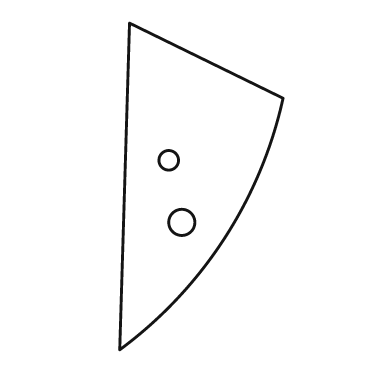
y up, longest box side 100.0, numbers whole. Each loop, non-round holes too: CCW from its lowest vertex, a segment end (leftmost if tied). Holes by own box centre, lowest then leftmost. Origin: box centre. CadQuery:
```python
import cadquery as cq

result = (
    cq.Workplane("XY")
    .moveTo(-25.0, -50.0)
    .threePointArc((7.0, -16.0), (25.0, 27.0))
    .lineTo(-22.0, 50.0)
    .close()
    .moveTo(-6.0, -11.0)
    .circle(4.0)
    .moveTo(-10.0, 8.0)
    .circle(3.0)
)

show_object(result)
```